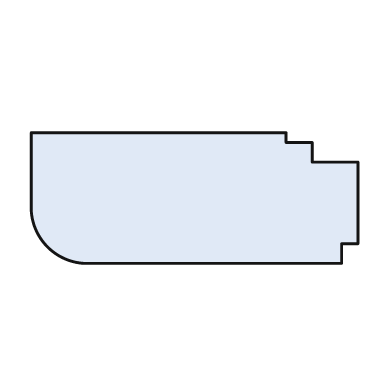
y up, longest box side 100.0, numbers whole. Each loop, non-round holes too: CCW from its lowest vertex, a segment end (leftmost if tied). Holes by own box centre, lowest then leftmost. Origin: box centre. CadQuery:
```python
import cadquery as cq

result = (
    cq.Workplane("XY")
    .moveTo(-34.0, -20.0)
    .lineTo(45.0, -20.0)
    .lineTo(45.0, -14.0)
    .lineTo(50.0, -14.0)
    .lineTo(50.0, 11.0)
    .lineTo(36.0, 11.0)
    .lineTo(36.0, 17.0)
    .lineTo(28.0, 17.0)
    .lineTo(28.0, 20.0)
    .lineTo(-50.0, 20.0)
    .lineTo(-50.0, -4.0)
    .threePointArc((-45.0, -15.0), (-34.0, -20.0))
    .close()
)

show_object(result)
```